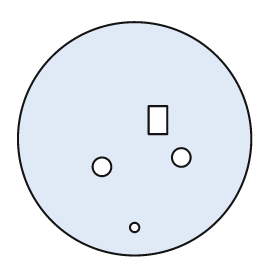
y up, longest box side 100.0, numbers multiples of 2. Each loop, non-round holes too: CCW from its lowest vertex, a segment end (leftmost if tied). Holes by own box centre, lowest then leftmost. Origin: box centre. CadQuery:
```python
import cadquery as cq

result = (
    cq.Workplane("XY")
    .moveTo(0.0, 0.0)
    .circle(50.0)
    .moveTo(0.0, -38.0)
    .circle(2.0)
    .moveTo(-14.0, -12.0)
    .circle(4.0)
    .moveTo(20.0, -8.0)
    .circle(4.0)
    .moveTo(6.0, 2.0)
    .lineTo(14.0, 2.0)
    .lineTo(14.0, 14.0)
    .lineTo(6.0, 14.0)
    .close()
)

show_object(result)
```